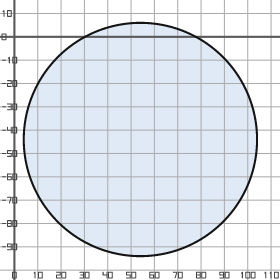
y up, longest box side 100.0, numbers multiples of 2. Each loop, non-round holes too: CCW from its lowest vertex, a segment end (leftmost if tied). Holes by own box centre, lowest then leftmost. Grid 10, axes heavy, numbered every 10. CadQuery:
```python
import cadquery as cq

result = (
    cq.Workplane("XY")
    .moveTo(54.0, -44.0)
    .circle(50.0)
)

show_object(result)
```